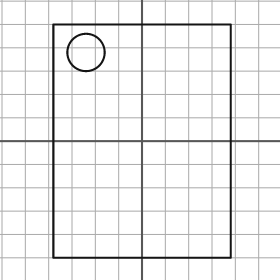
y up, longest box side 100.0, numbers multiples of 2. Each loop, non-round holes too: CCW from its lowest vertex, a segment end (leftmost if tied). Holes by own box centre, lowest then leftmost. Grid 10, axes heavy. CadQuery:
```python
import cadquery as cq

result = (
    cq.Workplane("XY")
    .moveTo(-38.0, -50.0)
    .lineTo(38.0, -50.0)
    .lineTo(38.0, 50.0)
    .lineTo(-38.0, 50.0)
    .close()
    .moveTo(-24.0, 38.0)
    .circle(8.0)
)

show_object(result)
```